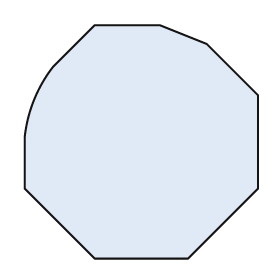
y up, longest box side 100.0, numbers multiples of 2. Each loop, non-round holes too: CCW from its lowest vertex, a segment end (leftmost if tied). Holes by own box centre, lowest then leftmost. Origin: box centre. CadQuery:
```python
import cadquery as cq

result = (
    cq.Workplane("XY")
    .moveTo(-20.0, -50.0)
    .lineTo(20.0, -50.0)
    .lineTo(50.0, -20.0)
    .lineTo(50.0, 20.0)
    .lineTo(28.0, 42.0)
    .lineTo(8.0, 50.0)
    .lineTo(-20.0, 50.0)
    .lineTo(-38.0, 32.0)
    .threePointArc((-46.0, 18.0), (-50.0, 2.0))
    .lineTo(-50.0, -20.0)
    .close()
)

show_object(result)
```